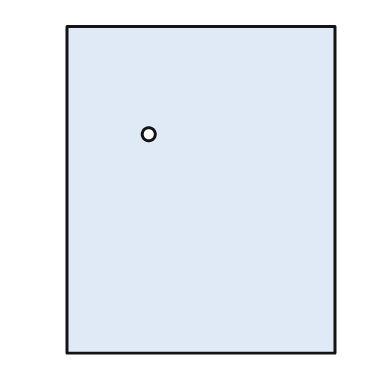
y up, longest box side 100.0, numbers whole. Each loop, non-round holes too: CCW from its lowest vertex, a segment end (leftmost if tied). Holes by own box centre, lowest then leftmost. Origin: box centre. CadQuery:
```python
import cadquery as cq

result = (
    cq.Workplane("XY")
    .moveTo(-41.0, -50.0)
    .lineTo(41.0, -50.0)
    .lineTo(41.0, 50.0)
    .lineTo(-41.0, 50.0)
    .close()
    .moveTo(-16.0, 17.0)
    .circle(2.0)
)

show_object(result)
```